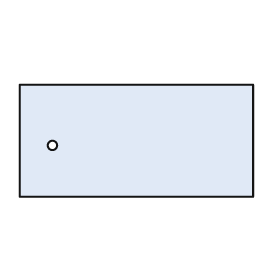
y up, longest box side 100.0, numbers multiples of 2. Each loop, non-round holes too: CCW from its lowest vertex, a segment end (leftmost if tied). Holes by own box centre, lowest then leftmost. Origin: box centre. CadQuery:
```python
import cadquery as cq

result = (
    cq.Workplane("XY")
    .moveTo(-50.0, -24.0)
    .lineTo(50.0, -24.0)
    .lineTo(50.0, 24.0)
    .lineTo(-50.0, 24.0)
    .close()
    .moveTo(-36.0, -2.0)
    .circle(2.0)
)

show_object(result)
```